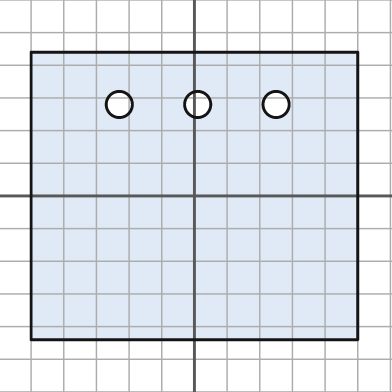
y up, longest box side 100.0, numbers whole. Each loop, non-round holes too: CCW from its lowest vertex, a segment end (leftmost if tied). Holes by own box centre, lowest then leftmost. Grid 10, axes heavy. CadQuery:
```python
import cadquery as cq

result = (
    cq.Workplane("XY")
    .moveTo(-50.0, -44.0)
    .lineTo(50.0, -44.0)
    .lineTo(50.0, 44.0)
    .lineTo(-50.0, 44.0)
    .close()
    .moveTo(-23.0, 28.0)
    .circle(4.0)
    .moveTo(1.0, 28.0)
    .circle(4.0)
    .moveTo(25.0, 28.0)
    .circle(4.0)
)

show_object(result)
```